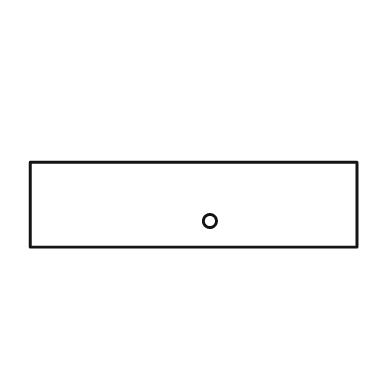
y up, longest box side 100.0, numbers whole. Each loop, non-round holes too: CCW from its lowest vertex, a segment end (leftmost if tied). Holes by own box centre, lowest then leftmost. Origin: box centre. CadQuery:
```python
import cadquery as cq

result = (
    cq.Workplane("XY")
    .moveTo(-50.0, -13.0)
    .lineTo(50.0, -13.0)
    .lineTo(50.0, 13.0)
    .lineTo(-50.0, 13.0)
    .close()
    .moveTo(5.0, -5.0)
    .circle(2.0)
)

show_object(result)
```